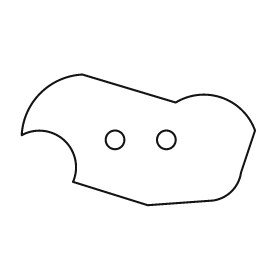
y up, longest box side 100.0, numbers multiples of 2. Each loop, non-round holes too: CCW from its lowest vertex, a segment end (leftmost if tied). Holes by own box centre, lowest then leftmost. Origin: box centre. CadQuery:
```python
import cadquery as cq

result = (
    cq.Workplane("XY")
    .moveTo(4.0, -28.0)
    .lineTo(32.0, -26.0)
    .threePointArc((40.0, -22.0), (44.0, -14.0))
    .lineTo(50.0, 4.0)
    .threePointArc((36.0, 18.0), (16.0, 16.0))
    .lineTo(-24.0, 28.0)
    .threePointArc((-42.0, 20.0), (-50.0, 2.0))
    .threePointArc((-32.0, 0.0), (-28.0, -18.0))
    .close()
    .moveTo(-10.0, 0.0)
    .circle(4.0)
    .moveTo(12.0, 0.0)
    .circle(4.0)
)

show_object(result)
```